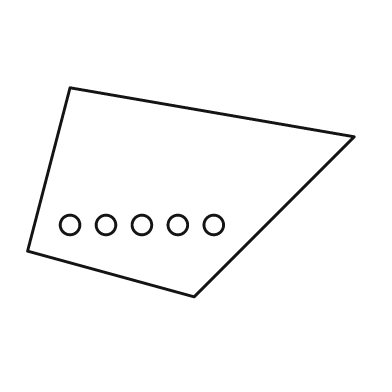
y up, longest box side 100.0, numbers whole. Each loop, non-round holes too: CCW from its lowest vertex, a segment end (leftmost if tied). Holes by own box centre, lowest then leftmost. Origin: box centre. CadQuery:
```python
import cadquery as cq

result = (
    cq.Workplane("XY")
    .moveTo(1.0, -32.0)
    .lineTo(50.0, 17.0)
    .lineTo(-37.0, 32.0)
    .lineTo(-50.0, -18.0)
    .close()
    .moveTo(-37.0, -10.0)
    .circle(3.0)
    .moveTo(-26.0, -10.0)
    .circle(3.0)
    .moveTo(-15.0, -10.0)
    .circle(3.0)
    .moveTo(-4.0, -10.0)
    .circle(3.0)
    .moveTo(7.0, -10.0)
    .circle(3.0)
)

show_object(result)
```